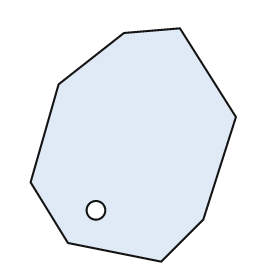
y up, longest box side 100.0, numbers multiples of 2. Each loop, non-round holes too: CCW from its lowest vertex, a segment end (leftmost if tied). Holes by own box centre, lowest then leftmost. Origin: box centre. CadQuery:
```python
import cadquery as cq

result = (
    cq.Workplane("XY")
    .moveTo(12.0, -50.0)
    .lineTo(30.0, -32.0)
    .lineTo(44.0, 12.0)
    .lineTo(20.0, 50.0)
    .lineTo(-4.0, 48.0)
    .lineTo(-32.0, 26.0)
    .lineTo(-44.0, -16.0)
    .lineTo(-28.0, -42.0)
    .close()
    .moveTo(-16.0, -28.0)
    .circle(4.0)
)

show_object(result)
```